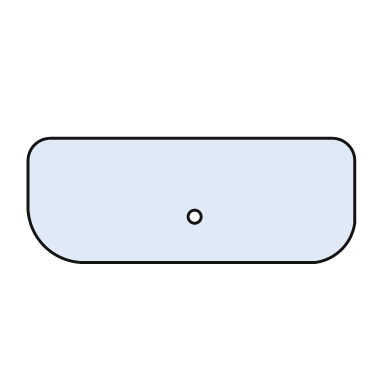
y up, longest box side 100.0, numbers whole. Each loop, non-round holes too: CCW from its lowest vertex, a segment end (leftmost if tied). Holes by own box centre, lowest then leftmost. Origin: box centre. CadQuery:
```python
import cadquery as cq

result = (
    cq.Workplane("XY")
    .moveTo(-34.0, -19.0)
    .lineTo(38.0, -19.0)
    .threePointArc((46.0, -15.0), (50.0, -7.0))
    .lineTo(50.0, 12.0)
    .threePointArc((48.0, 17.0), (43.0, 19.0))
    .lineTo(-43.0, 19.0)
    .threePointArc((-48.0, 17.0), (-50.0, 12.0))
    .lineTo(-50.0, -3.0)
    .threePointArc((-45.0, -14.0), (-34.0, -19.0))
    .close()
    .moveTo(1.0, -5.0)
    .circle(2.0)
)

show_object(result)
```